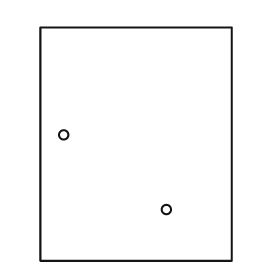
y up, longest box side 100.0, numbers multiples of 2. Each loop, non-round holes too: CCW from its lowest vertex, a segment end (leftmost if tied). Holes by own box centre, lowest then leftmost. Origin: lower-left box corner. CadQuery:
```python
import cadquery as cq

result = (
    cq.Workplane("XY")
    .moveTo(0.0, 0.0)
    .lineTo(82.0, 0.0)
    .lineTo(82.0, 100.0)
    .lineTo(0.0, 100.0)
    .close()
    .moveTo(54.0, 22.0)
    .circle(2.0)
    .moveTo(10.0, 54.0)
    .circle(2.0)
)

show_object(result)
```